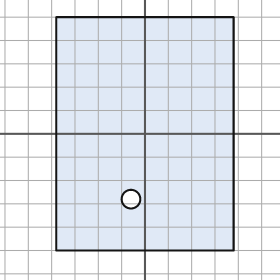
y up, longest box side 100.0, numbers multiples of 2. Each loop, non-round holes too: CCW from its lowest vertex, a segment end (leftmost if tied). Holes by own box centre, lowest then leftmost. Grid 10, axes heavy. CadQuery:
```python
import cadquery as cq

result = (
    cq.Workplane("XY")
    .moveTo(-38.0, -50.0)
    .lineTo(38.0, -50.0)
    .lineTo(38.0, 50.0)
    .lineTo(-38.0, 50.0)
    .close()
    .moveTo(-6.0, -28.0)
    .circle(4.0)
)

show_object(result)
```